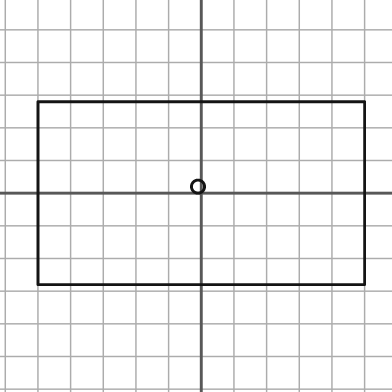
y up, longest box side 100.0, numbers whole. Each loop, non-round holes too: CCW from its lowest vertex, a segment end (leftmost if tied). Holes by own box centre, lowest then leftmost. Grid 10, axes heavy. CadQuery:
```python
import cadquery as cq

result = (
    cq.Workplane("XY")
    .moveTo(-50.0, -28.0)
    .lineTo(50.0, -28.0)
    .lineTo(50.0, 28.0)
    .lineTo(-50.0, 28.0)
    .close()
    .moveTo(-1.0, 2.0)
    .circle(2.0)
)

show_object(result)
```